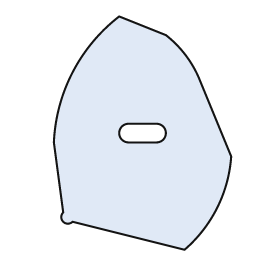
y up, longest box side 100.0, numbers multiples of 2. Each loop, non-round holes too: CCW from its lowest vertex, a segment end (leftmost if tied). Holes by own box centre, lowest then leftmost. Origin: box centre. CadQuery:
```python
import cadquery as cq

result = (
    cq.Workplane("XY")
    .moveTo(18.0, -50.0)
    .threePointArc((32.0, -32.0), (38.0, -10.0))
    .lineTo(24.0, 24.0)
    .threePointArc((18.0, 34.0), (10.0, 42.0))
    .lineTo(-10.0, 50.0)
    .threePointArc((-30.0, 26.0), (-38.0, -4.0))
    .lineTo(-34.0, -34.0)
    .threePointArc((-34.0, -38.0), (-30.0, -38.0))
    .close()
    .moveTo(-6.0, -4.0)
    .lineTo(6.0, -4.0)
    .threePointArc((10.0, 0.0), (6.0, 4.0))
    .lineTo(-6.0, 4.0)
    .threePointArc((-10.0, 0.0), (-6.0, -4.0))
    .close()
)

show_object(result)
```